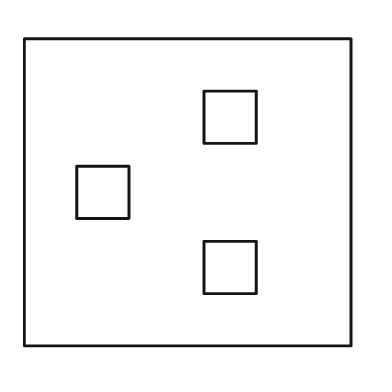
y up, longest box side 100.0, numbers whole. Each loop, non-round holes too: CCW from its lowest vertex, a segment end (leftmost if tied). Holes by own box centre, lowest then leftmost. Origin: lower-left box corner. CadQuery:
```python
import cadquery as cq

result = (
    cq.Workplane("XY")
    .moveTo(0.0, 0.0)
    .lineTo(100.0, 0.0)
    .lineTo(100.0, 94.0)
    .lineTo(0.0, 94.0)
    .close()
    .moveTo(55.0, 16.0)
    .lineTo(71.0, 16.0)
    .lineTo(71.0, 32.0)
    .lineTo(55.0, 32.0)
    .close()
    .moveTo(16.0, 39.0)
    .lineTo(32.0, 39.0)
    .lineTo(32.0, 55.0)
    .lineTo(16.0, 55.0)
    .close()
    .moveTo(55.0, 62.0)
    .lineTo(71.0, 62.0)
    .lineTo(71.0, 78.0)
    .lineTo(55.0, 78.0)
    .close()
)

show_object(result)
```